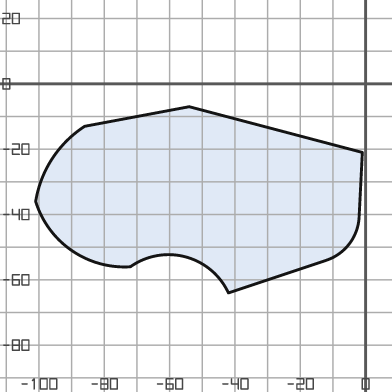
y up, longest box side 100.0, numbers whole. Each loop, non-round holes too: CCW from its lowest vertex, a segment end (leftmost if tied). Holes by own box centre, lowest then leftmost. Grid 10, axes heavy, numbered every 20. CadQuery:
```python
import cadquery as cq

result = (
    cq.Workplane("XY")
    .moveTo(-42.0, -64.0)
    .lineTo(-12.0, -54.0)
    .threePointArc((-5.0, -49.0), (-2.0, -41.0))
    .lineTo(-1.0, -21.0)
    .lineTo(-54.0, -7.0)
    .lineTo(-86.0, -13.0)
    .threePointArc((-96.0, -23.0), (-101.0, -36.0))
    .threePointArc((-90.0, -51.0), (-72.0, -56.0))
    .threePointArc((-55.0, -53.0), (-42.0, -64.0))
    .close()
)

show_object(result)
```